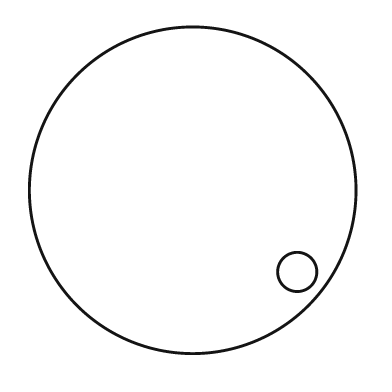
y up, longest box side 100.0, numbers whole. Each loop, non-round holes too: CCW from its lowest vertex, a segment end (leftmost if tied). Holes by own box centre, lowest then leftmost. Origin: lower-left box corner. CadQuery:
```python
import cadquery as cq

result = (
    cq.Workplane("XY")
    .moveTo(50.0, 50.0)
    .circle(50.0)
    .moveTo(82.0, 25.0)
    .circle(6.0)
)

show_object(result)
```